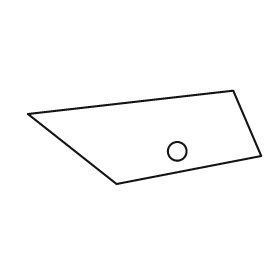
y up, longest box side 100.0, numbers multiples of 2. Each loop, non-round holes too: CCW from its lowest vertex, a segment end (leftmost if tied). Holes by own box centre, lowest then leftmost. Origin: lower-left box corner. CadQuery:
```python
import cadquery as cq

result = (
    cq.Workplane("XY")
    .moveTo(38.0, 0.0)
    .lineTo(100.0, 12.0)
    .lineTo(88.0, 40.0)
    .lineTo(0.0, 30.0)
    .close()
    .moveTo(64.0, 14.0)
    .circle(4.0)
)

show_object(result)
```